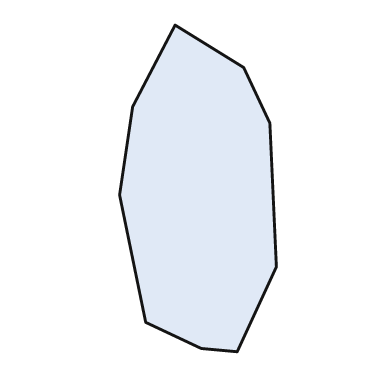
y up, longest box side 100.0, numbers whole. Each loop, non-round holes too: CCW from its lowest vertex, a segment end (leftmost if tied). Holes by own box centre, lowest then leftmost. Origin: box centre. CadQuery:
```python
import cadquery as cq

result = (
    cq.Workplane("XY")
    .moveTo(12.0, -50.0)
    .lineTo(24.0, -24.0)
    .lineTo(22.0, 20.0)
    .lineTo(14.0, 37.0)
    .lineTo(-7.0, 50.0)
    .lineTo(-20.0, 25.0)
    .lineTo(-24.0, -2.0)
    .lineTo(-16.0, -41.0)
    .lineTo(1.0, -49.0)
    .close()
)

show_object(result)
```